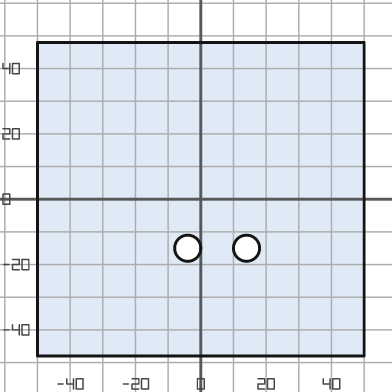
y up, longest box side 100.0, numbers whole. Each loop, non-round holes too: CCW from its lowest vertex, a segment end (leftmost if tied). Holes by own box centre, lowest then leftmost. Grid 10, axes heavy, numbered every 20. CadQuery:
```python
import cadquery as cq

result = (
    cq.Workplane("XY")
    .moveTo(-50.0, -48.0)
    .lineTo(50.0, -48.0)
    .lineTo(50.0, 48.0)
    .lineTo(-50.0, 48.0)
    .close()
    .moveTo(-4.0, -15.0)
    .circle(4.0)
    .moveTo(14.0, -15.0)
    .circle(4.0)
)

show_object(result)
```